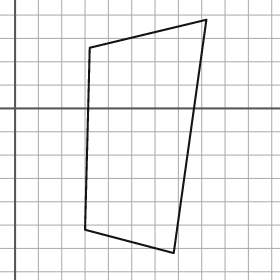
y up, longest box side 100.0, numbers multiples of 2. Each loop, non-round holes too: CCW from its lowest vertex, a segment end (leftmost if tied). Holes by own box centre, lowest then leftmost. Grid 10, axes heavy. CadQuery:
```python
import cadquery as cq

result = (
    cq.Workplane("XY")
    .moveTo(68.0, -62.0)
    .lineTo(82.0, 38.0)
    .lineTo(32.0, 26.0)
    .lineTo(30.0, -52.0)
    .close()
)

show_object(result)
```